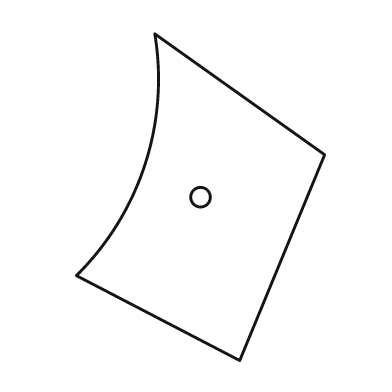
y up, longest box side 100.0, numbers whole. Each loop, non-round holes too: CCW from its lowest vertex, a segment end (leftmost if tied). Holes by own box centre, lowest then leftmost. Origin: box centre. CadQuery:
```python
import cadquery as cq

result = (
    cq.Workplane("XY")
    .moveTo(12.0, -50.0)
    .lineTo(38.0, 13.0)
    .lineTo(-14.0, 50.0)
    .threePointArc((-17.0, 10.0), (-38.0, -24.0))
    .close()
    .moveTo(0.0, 0.0)
    .circle(3.0)
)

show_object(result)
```